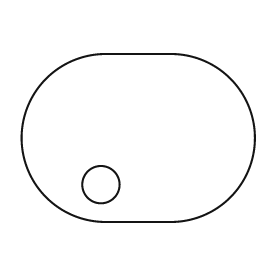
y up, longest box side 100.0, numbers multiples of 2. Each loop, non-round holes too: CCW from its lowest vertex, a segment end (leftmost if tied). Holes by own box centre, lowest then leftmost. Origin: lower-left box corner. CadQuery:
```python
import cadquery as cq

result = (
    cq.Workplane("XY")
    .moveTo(36.0, 0.0)
    .lineTo(64.0, 0.0)
    .threePointArc((100.0, 36.0), (64.0, 72.0))
    .lineTo(36.0, 72.0)
    .threePointArc((0.0, 36.0), (36.0, 0.0))
    .close()
    .moveTo(34.0, 16.0)
    .circle(8.0)
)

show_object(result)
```